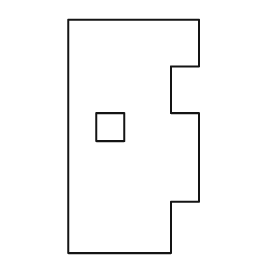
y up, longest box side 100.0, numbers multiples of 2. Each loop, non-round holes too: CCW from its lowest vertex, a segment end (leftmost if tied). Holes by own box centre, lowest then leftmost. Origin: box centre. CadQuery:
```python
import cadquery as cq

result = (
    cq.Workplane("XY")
    .moveTo(-28.0, -50.0)
    .lineTo(16.0, -50.0)
    .lineTo(16.0, -28.0)
    .lineTo(28.0, -28.0)
    .lineTo(28.0, 10.0)
    .lineTo(16.0, 10.0)
    .lineTo(16.0, 30.0)
    .lineTo(28.0, 30.0)
    .lineTo(28.0, 50.0)
    .lineTo(-28.0, 50.0)
    .close()
    .moveTo(-16.0, -2.0)
    .lineTo(-4.0, -2.0)
    .lineTo(-4.0, 10.0)
    .lineTo(-16.0, 10.0)
    .close()
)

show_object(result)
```